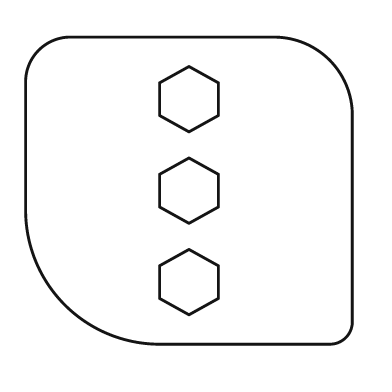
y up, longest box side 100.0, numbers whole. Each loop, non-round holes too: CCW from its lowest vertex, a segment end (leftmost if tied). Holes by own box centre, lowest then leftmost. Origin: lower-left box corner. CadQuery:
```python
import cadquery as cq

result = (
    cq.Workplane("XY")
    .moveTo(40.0, 0.0)
    .lineTo(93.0, 0.0)
    .threePointArc((98.0, 2.0), (100.0, 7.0))
    .lineTo(100.0, 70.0)
    .threePointArc((93.0, 87.0), (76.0, 94.0))
    .lineTo(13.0, 94.0)
    .threePointArc((4.0, 90.0), (0.0, 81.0))
    .lineTo(0.0, 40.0)
    .threePointArc((12.0, 12.0), (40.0, 0.0))
    .close()
    .moveTo(50.0, 9.0)
    .lineTo(59.0, 14.0)
    .lineTo(59.0, 24.0)
    .lineTo(50.0, 29.0)
    .lineTo(41.0, 24.0)
    .lineTo(41.0, 14.0)
    .close()
    .moveTo(50.0, 37.0)
    .lineTo(59.0, 42.0)
    .lineTo(59.0, 52.0)
    .lineTo(50.0, 57.0)
    .lineTo(41.0, 52.0)
    .lineTo(41.0, 42.0)
    .close()
    .moveTo(50.0, 65.0)
    .lineTo(59.0, 70.0)
    .lineTo(59.0, 80.0)
    .lineTo(50.0, 85.0)
    .lineTo(41.0, 80.0)
    .lineTo(41.0, 70.0)
    .close()
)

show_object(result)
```